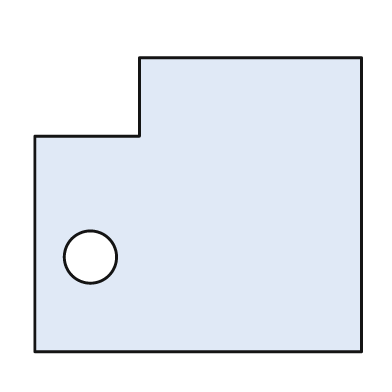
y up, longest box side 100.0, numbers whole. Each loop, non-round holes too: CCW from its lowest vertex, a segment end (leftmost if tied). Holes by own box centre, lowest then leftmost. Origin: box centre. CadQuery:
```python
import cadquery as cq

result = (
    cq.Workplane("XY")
    .moveTo(-50.0, -45.0)
    .lineTo(50.0, -45.0)
    .lineTo(50.0, 45.0)
    .lineTo(-18.0, 45.0)
    .lineTo(-18.0, 21.0)
    .lineTo(-50.0, 21.0)
    .close()
    .moveTo(-33.0, -16.0)
    .circle(8.0)
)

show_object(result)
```